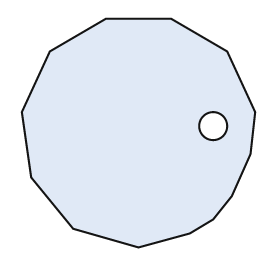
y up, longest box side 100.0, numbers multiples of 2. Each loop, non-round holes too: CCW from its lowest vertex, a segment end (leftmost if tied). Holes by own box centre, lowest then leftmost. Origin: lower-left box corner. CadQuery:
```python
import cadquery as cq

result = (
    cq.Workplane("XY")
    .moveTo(50.0, 0.0)
    .lineTo(72.0, 6.0)
    .lineTo(82.0, 12.0)
    .lineTo(90.0, 22.0)
    .lineTo(98.0, 40.0)
    .lineTo(100.0, 58.0)
    .lineTo(88.0, 84.0)
    .lineTo(64.0, 98.0)
    .lineTo(36.0, 98.0)
    .lineTo(12.0, 84.0)
    .lineTo(0.0, 58.0)
    .lineTo(4.0, 30.0)
    .lineTo(22.0, 8.0)
    .close()
    .moveTo(82.0, 52.0)
    .circle(6.0)
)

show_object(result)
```